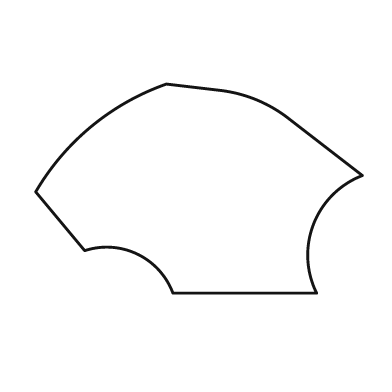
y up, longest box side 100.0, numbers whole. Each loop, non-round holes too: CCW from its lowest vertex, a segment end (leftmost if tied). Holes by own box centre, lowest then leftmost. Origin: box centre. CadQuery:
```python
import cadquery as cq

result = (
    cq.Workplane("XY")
    .moveTo(-8.0, -32.0)
    .lineTo(36.0, -32.0)
    .threePointArc((35.0, -11.0), (50.0, 4.0))
    .lineTo(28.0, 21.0)
    .threePointArc((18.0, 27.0), (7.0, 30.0))
    .lineTo(-10.0, 32.0)
    .threePointArc((-33.0, 19.0), (-50.0, -1.0))
    .lineTo(-35.0, -19.0)
    .threePointArc((-19.0, -20.0), (-8.0, -32.0))
    .close()
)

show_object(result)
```